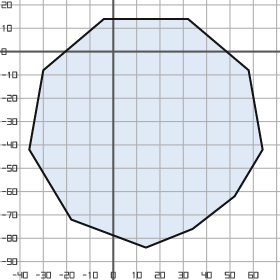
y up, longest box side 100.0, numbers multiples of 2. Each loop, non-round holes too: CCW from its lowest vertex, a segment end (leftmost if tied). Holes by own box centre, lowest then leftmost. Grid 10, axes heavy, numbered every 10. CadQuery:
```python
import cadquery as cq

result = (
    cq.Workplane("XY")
    .moveTo(14.0, -84.0)
    .lineTo(34.0, -76.0)
    .lineTo(52.0, -62.0)
    .lineTo(64.0, -42.0)
    .lineTo(58.0, -8.0)
    .lineTo(32.0, 14.0)
    .lineTo(-4.0, 14.0)
    .lineTo(-30.0, -8.0)
    .lineTo(-36.0, -42.0)
    .lineTo(-18.0, -72.0)
    .close()
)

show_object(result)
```